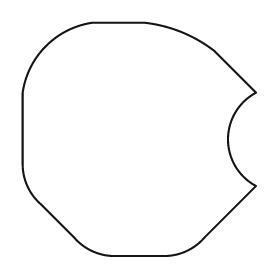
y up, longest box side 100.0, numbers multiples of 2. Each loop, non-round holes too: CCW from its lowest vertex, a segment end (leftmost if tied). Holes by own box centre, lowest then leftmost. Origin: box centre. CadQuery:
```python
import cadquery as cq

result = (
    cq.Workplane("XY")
    .moveTo(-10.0, -50.0)
    .lineTo(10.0, -50.0)
    .threePointArc((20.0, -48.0), (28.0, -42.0))
    .lineTo(50.0, -20.0)
    .threePointArc((38.0, 0.0), (50.0, 20.0))
    .lineTo(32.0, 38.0)
    .threePointArc((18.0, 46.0), (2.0, 50.0))
    .lineTo(-20.0, 50.0)
    .threePointArc((-40.0, 40.0), (-50.0, 20.0))
    .lineTo(-50.0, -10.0)
    .threePointArc((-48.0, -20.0), (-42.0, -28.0))
    .lineTo(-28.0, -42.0)
    .threePointArc((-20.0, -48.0), (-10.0, -50.0))
    .close()
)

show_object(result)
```